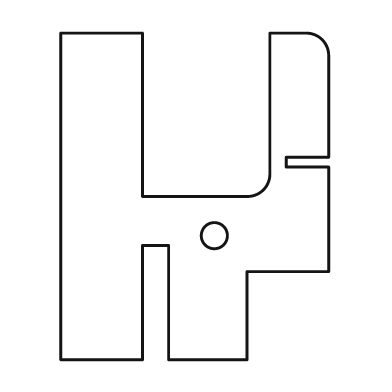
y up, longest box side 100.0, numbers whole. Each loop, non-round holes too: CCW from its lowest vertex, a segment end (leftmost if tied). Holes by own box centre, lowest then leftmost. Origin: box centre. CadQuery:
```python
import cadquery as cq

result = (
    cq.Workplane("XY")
    .moveTo(-41.0, -50.0)
    .lineTo(-16.0, -50.0)
    .lineTo(-16.0, -15.0)
    .lineTo(-8.0, -15.0)
    .lineTo(-8.0, -50.0)
    .lineTo(16.0, -50.0)
    .lineTo(16.0, -23.0)
    .lineTo(41.0, -23.0)
    .lineTo(41.0, 9.0)
    .lineTo(28.0, 9.0)
    .lineTo(28.0, 12.0)
    .lineTo(41.0, 12.0)
    .lineTo(41.0, 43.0)
    .threePointArc((39.0, 48.0), (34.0, 50.0))
    .lineTo(23.0, 50.0)
    .lineTo(23.0, 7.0)
    .threePointArc((21.0, 2.0), (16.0, 0.0))
    .lineTo(-16.0, 0.0)
    .lineTo(-16.0, 50.0)
    .lineTo(-41.0, 50.0)
    .close()
    .moveTo(6.0, -12.0)
    .circle(4.0)
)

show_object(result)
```